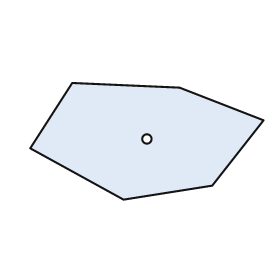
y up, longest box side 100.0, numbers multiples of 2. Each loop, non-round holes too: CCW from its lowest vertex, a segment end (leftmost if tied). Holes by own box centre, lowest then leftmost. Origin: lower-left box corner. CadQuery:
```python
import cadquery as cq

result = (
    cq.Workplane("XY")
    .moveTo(40.0, 0.0)
    .lineTo(78.0, 6.0)
    .lineTo(100.0, 34.0)
    .lineTo(64.0, 48.0)
    .lineTo(18.0, 50.0)
    .lineTo(0.0, 22.0)
    .close()
    .moveTo(50.0, 26.0)
    .circle(2.0)
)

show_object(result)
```